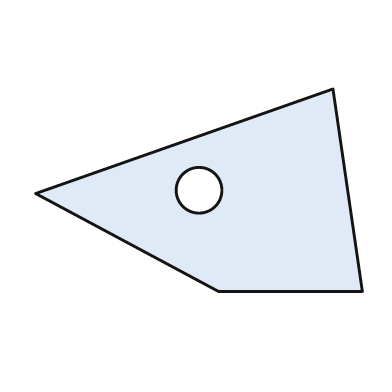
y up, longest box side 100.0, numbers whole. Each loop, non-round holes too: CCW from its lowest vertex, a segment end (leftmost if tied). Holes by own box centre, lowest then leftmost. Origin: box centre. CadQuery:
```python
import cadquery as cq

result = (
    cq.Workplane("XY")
    .moveTo(6.0, -31.0)
    .lineTo(50.0, -31.0)
    .lineTo(41.0, 31.0)
    .lineTo(-50.0, -1.0)
    .close()
    .moveTo(0.0, 0.0)
    .circle(7.0)
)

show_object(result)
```